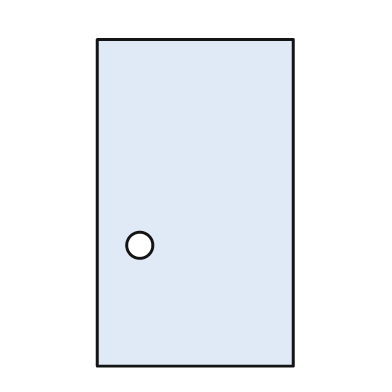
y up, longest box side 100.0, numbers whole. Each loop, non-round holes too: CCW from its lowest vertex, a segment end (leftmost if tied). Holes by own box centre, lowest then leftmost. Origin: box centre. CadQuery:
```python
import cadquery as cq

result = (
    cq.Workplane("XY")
    .moveTo(-30.0, -50.0)
    .lineTo(30.0, -50.0)
    .lineTo(30.0, 50.0)
    .lineTo(-30.0, 50.0)
    .close()
    .moveTo(-17.0, -13.0)
    .circle(4.0)
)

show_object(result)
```